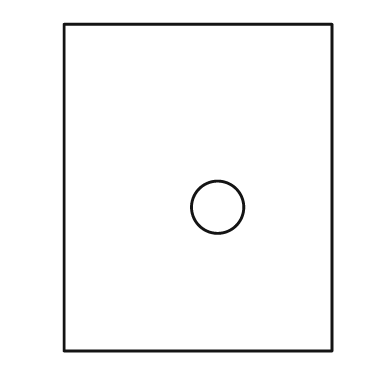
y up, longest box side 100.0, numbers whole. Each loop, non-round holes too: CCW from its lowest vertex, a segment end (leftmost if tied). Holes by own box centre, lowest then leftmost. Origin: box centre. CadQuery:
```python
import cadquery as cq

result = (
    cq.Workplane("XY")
    .moveTo(-41.0, -50.0)
    .lineTo(41.0, -50.0)
    .lineTo(41.0, 50.0)
    .lineTo(-41.0, 50.0)
    .close()
    .moveTo(6.0, -6.0)
    .circle(8.0)
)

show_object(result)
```